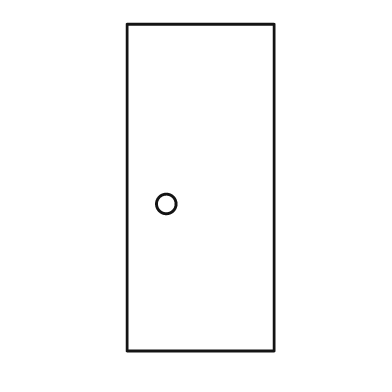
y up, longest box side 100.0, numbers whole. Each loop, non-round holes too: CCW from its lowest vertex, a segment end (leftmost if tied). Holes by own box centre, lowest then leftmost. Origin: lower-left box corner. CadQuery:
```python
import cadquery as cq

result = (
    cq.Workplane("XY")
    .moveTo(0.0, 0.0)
    .lineTo(45.0, 0.0)
    .lineTo(45.0, 100.0)
    .lineTo(0.0, 100.0)
    .close()
    .moveTo(12.0, 45.0)
    .circle(3.0)
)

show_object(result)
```